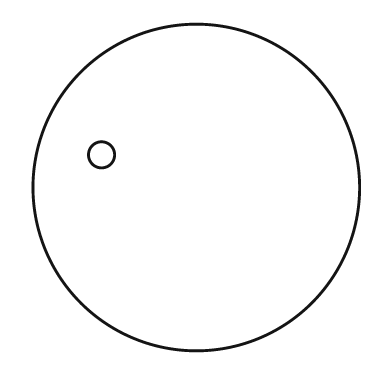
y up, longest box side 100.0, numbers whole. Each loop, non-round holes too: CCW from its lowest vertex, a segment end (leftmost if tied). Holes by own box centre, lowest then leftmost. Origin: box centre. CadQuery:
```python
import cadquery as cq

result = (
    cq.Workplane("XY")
    .moveTo(0.0, 0.0)
    .circle(50.0)
    .moveTo(-29.0, 10.0)
    .circle(4.0)
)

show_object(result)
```